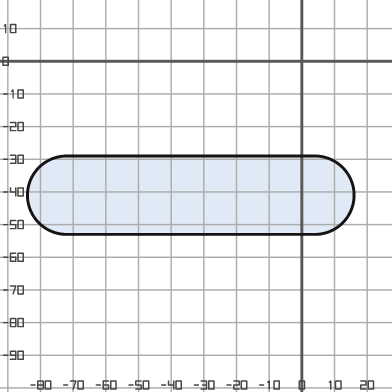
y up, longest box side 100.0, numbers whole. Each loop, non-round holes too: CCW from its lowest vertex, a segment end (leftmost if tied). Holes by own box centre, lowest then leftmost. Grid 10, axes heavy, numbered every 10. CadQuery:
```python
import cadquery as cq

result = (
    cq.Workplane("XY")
    .moveTo(-72.0, -53.0)
    .lineTo(4.0, -53.0)
    .threePointArc((16.0, -41.0), (4.0, -29.0))
    .lineTo(-72.0, -29.0)
    .threePointArc((-84.0, -41.0), (-72.0, -53.0))
    .close()
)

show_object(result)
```